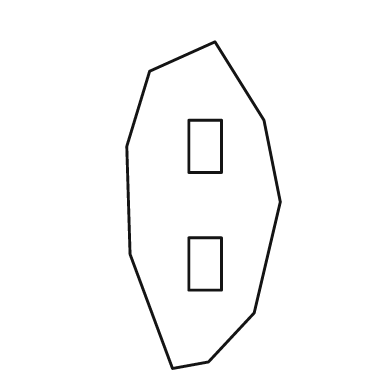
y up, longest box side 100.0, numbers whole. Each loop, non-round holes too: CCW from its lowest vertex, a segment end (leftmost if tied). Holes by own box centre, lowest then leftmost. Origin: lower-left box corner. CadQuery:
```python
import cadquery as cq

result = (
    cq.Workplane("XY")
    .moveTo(14.0, 0.0)
    .lineTo(25.0, 2.0)
    .lineTo(39.0, 17.0)
    .lineTo(47.0, 51.0)
    .lineTo(42.0, 76.0)
    .lineTo(27.0, 100.0)
    .lineTo(7.0, 91.0)
    .lineTo(0.0, 68.0)
    .lineTo(1.0, 35.0)
    .close()
    .moveTo(19.0, 24.0)
    .lineTo(29.0, 24.0)
    .lineTo(29.0, 40.0)
    .lineTo(19.0, 40.0)
    .close()
    .moveTo(19.0, 60.0)
    .lineTo(29.0, 60.0)
    .lineTo(29.0, 76.0)
    .lineTo(19.0, 76.0)
    .close()
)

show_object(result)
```